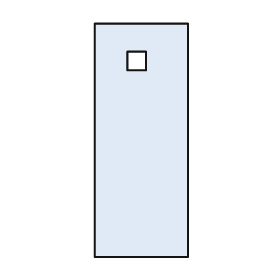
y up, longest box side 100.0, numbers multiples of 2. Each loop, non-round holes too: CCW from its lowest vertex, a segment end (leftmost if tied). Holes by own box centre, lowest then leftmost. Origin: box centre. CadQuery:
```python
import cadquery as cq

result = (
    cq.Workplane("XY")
    .moveTo(-20.0, -50.0)
    .lineTo(20.0, -50.0)
    .lineTo(20.0, 50.0)
    .lineTo(-20.0, 50.0)
    .close()
    .moveTo(-6.0, 30.0)
    .lineTo(2.0, 30.0)
    .lineTo(2.0, 38.0)
    .lineTo(-6.0, 38.0)
    .close()
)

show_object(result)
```